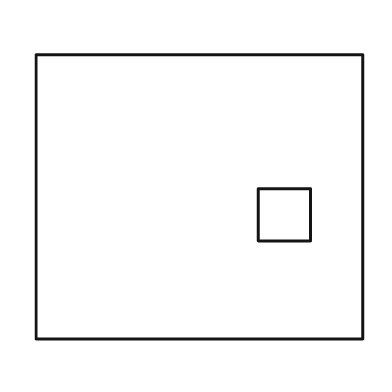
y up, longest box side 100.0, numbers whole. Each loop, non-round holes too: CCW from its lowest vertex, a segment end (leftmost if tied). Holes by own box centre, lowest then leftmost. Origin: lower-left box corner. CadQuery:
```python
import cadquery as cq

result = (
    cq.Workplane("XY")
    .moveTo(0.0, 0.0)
    .lineTo(100.0, 0.0)
    .lineTo(100.0, 87.0)
    .lineTo(0.0, 87.0)
    .close()
    .moveTo(68.0, 30.0)
    .lineTo(84.0, 30.0)
    .lineTo(84.0, 46.0)
    .lineTo(68.0, 46.0)
    .close()
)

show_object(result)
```